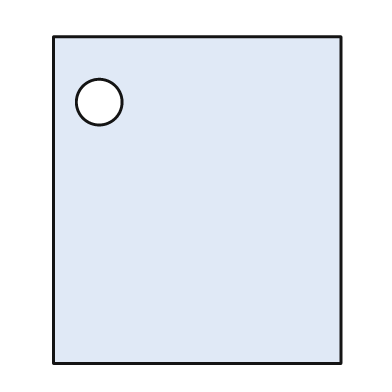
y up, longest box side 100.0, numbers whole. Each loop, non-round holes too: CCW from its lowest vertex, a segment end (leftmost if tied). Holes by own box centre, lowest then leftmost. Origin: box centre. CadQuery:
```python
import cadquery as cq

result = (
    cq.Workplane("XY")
    .moveTo(-44.0, -50.0)
    .lineTo(44.0, -50.0)
    .lineTo(44.0, 50.0)
    .lineTo(-44.0, 50.0)
    .close()
    .moveTo(-30.0, 30.0)
    .circle(7.0)
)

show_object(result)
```